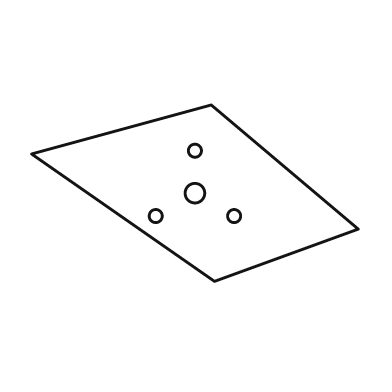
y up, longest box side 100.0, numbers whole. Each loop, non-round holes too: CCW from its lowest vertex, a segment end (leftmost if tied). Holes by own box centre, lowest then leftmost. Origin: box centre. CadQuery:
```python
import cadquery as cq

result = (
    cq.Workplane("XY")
    .moveTo(6.0, -27.0)
    .lineTo(50.0, -11.0)
    .lineTo(5.0, 27.0)
    .lineTo(-50.0, 12.0)
    .close()
    .moveTo(-12.0, -7.0)
    .circle(2.0)
    .moveTo(12.0, -7.0)
    .circle(2.0)
    .moveTo(0.0, 0.0)
    .circle(3.0)
    .moveTo(0.0, 13.0)
    .circle(2.0)
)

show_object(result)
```